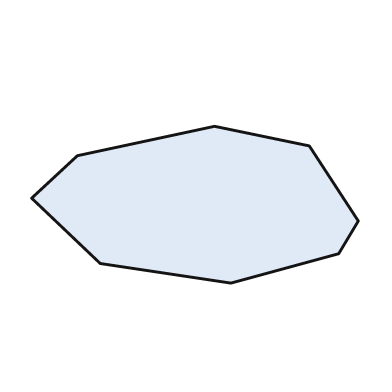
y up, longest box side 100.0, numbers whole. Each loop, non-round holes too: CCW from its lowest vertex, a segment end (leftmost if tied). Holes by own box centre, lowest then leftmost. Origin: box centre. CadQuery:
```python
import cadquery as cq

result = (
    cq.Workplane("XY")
    .moveTo(11.0, -24.0)
    .lineTo(44.0, -15.0)
    .lineTo(50.0, -5.0)
    .lineTo(35.0, 18.0)
    .lineTo(6.0, 24.0)
    .lineTo(-36.0, 15.0)
    .lineTo(-50.0, 2.0)
    .lineTo(-29.0, -18.0)
    .close()
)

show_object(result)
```